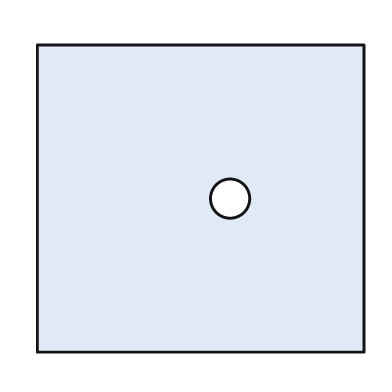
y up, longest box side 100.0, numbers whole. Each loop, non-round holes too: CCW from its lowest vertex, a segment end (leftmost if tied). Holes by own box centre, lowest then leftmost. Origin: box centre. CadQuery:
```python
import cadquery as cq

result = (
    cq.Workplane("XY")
    .moveTo(-50.0, -47.0)
    .lineTo(50.0, -47.0)
    .lineTo(50.0, 47.0)
    .lineTo(-50.0, 47.0)
    .close()
    .moveTo(9.0, 0.0)
    .circle(6.0)
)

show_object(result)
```